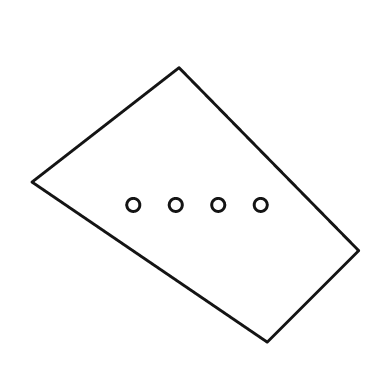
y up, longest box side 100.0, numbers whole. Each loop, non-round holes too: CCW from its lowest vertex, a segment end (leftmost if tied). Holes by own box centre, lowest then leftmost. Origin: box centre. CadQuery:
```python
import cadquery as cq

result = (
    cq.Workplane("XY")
    .moveTo(22.0, -42.0)
    .lineTo(50.0, -14.0)
    .lineTo(-5.0, 42.0)
    .lineTo(-50.0, 7.0)
    .close()
    .moveTo(-19.0, 0.0)
    .circle(2.0)
    .moveTo(-6.0, 0.0)
    .circle(2.0)
    .moveTo(7.0, 0.0)
    .circle(2.0)
    .moveTo(20.0, 0.0)
    .circle(2.0)
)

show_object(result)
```